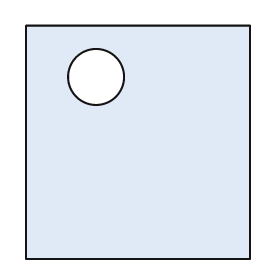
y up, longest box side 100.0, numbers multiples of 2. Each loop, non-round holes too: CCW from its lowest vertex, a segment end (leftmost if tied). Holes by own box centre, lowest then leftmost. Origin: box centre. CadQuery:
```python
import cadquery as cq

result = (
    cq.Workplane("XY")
    .moveTo(-48.0, -50.0)
    .lineTo(48.0, -50.0)
    .lineTo(48.0, 50.0)
    .lineTo(-48.0, 50.0)
    .close()
    .moveTo(-18.0, 28.0)
    .circle(12.0)
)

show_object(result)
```